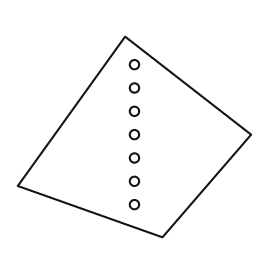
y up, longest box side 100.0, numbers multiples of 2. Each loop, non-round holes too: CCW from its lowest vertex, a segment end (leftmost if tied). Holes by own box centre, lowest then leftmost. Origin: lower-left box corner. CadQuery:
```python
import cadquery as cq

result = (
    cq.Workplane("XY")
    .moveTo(62.0, 0.0)
    .lineTo(100.0, 44.0)
    .lineTo(46.0, 86.0)
    .lineTo(0.0, 22.0)
    .close()
    .moveTo(50.0, 14.0)
    .circle(2.0)
    .moveTo(50.0, 24.0)
    .circle(2.0)
    .moveTo(50.0, 34.0)
    .circle(2.0)
    .moveTo(50.0, 44.0)
    .circle(2.0)
    .moveTo(50.0, 54.0)
    .circle(2.0)
    .moveTo(50.0, 64.0)
    .circle(2.0)
    .moveTo(50.0, 74.0)
    .circle(2.0)
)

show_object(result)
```